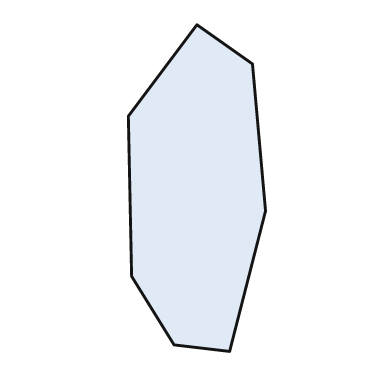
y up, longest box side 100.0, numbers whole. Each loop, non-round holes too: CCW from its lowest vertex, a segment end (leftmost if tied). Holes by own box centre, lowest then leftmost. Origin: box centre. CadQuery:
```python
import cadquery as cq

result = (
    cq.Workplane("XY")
    .moveTo(10.0, -50.0)
    .lineTo(21.0, -7.0)
    .lineTo(17.0, 38.0)
    .lineTo(0.0, 50.0)
    .lineTo(-21.0, 22.0)
    .lineTo(-20.0, -27.0)
    .lineTo(-7.0, -48.0)
    .close()
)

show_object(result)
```